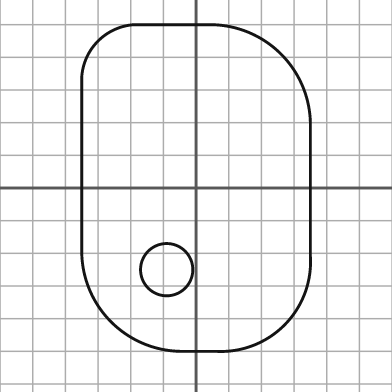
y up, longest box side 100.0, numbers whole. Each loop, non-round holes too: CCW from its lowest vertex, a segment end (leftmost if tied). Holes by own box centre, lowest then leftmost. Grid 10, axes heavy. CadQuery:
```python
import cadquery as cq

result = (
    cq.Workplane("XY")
    .moveTo(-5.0, -50.0)
    .lineTo(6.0, -50.0)
    .threePointArc((27.0, -42.0), (35.0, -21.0))
    .lineTo(35.0, 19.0)
    .threePointArc((26.0, 41.0), (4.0, 50.0))
    .lineTo(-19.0, 50.0)
    .threePointArc((-30.0, 45.0), (-35.0, 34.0))
    .lineTo(-35.0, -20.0)
    .threePointArc((-26.0, -41.0), (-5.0, -50.0))
    .close()
    .moveTo(-9.0, -25.0)
    .circle(8.0)
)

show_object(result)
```